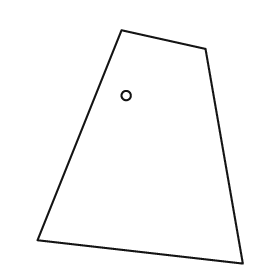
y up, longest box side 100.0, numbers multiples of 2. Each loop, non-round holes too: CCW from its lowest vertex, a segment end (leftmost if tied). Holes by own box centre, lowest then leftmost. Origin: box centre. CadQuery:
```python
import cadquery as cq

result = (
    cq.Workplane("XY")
    .moveTo(44.0, -50.0)
    .lineTo(28.0, 42.0)
    .lineTo(-8.0, 50.0)
    .lineTo(-44.0, -40.0)
    .close()
    .moveTo(-6.0, 22.0)
    .circle(2.0)
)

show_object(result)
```